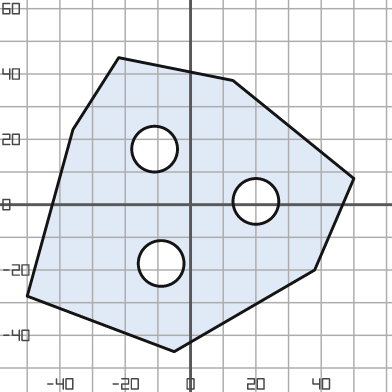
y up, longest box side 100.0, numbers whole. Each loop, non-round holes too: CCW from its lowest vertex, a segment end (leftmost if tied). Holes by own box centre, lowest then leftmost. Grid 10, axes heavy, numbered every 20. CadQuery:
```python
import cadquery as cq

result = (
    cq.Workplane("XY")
    .moveTo(-5.0, -45.0)
    .lineTo(38.0, -20.0)
    .lineTo(50.0, 8.0)
    .lineTo(13.0, 38.0)
    .lineTo(-22.0, 45.0)
    .lineTo(-36.0, 23.0)
    .lineTo(-50.0, -28.0)
    .close()
    .moveTo(-9.0, -18.0)
    .circle(7.0)
    .moveTo(20.0, 1.0)
    .circle(7.0)
    .moveTo(-11.0, 17.0)
    .circle(7.0)
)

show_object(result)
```